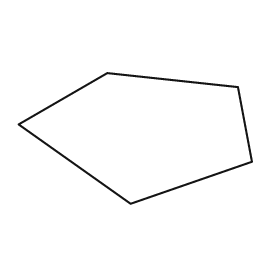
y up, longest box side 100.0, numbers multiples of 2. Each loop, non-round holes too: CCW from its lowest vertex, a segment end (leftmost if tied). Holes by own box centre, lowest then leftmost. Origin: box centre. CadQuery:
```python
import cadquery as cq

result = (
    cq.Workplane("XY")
    .moveTo(-2.0, -28.0)
    .lineTo(50.0, -10.0)
    .lineTo(44.0, 22.0)
    .lineTo(-12.0, 28.0)
    .lineTo(-50.0, 6.0)
    .close()
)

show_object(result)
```